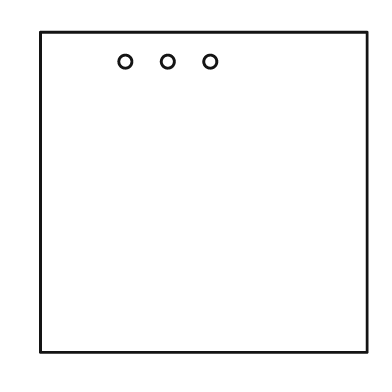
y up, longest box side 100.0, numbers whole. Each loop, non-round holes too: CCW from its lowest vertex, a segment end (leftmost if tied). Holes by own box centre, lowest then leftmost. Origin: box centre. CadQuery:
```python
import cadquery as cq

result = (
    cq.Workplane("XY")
    .moveTo(-50.0, -49.0)
    .lineTo(50.0, -49.0)
    .lineTo(50.0, 49.0)
    .lineTo(-50.0, 49.0)
    .close()
    .moveTo(-24.0, 40.0)
    .circle(2.0)
    .moveTo(-11.0, 40.0)
    .circle(2.0)
    .moveTo(2.0, 40.0)
    .circle(2.0)
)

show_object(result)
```